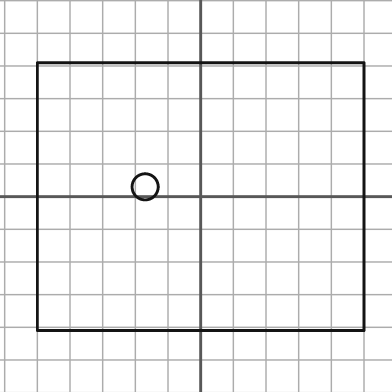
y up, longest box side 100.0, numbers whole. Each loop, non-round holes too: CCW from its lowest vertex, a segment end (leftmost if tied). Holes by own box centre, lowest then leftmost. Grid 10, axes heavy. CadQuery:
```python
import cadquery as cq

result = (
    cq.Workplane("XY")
    .moveTo(-50.0, -41.0)
    .lineTo(50.0, -41.0)
    .lineTo(50.0, 41.0)
    .lineTo(-50.0, 41.0)
    .close()
    .moveTo(-17.0, 3.0)
    .circle(4.0)
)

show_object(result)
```